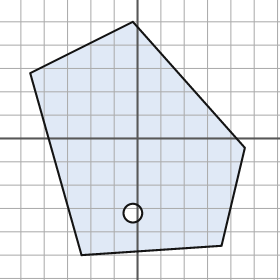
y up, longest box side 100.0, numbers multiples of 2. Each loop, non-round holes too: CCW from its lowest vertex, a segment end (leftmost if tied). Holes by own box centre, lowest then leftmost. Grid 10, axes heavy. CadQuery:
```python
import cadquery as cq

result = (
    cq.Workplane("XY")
    .moveTo(-24.0, -50.0)
    .lineTo(36.0, -46.0)
    .lineTo(46.0, -4.0)
    .lineTo(-2.0, 50.0)
    .lineTo(-46.0, 28.0)
    .close()
    .moveTo(-2.0, -32.0)
    .circle(4.0)
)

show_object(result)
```